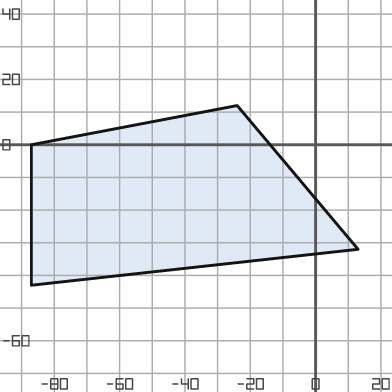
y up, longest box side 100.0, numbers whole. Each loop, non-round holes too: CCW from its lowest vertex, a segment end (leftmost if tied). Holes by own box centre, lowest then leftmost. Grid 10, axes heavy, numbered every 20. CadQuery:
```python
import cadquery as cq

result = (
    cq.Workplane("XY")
    .moveTo(-87.0, -43.0)
    .lineTo(13.0, -32.0)
    .lineTo(-24.0, 12.0)
    .lineTo(-87.0, 0.0)
    .close()
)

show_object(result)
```